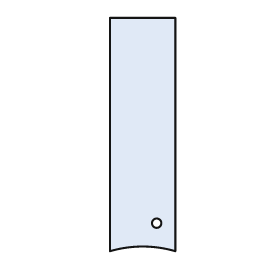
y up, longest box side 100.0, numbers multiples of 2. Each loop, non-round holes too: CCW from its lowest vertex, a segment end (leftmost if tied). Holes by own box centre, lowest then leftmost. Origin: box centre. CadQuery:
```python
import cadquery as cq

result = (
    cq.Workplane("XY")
    .moveTo(-14.0, -50.0)
    .threePointArc((0.0, -48.0), (14.0, -50.0))
    .lineTo(14.0, 50.0)
    .lineTo(-14.0, 50.0)
    .close()
    .moveTo(6.0, -38.0)
    .circle(2.0)
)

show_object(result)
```